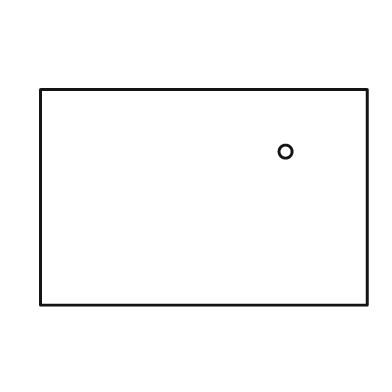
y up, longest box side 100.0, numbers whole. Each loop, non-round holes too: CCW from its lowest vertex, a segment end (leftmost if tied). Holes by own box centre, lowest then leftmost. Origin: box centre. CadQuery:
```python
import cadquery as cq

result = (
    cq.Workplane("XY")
    .moveTo(-50.0, -33.0)
    .lineTo(50.0, -33.0)
    .lineTo(50.0, 33.0)
    .lineTo(-50.0, 33.0)
    .close()
    .moveTo(25.0, 14.0)
    .circle(2.0)
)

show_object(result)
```